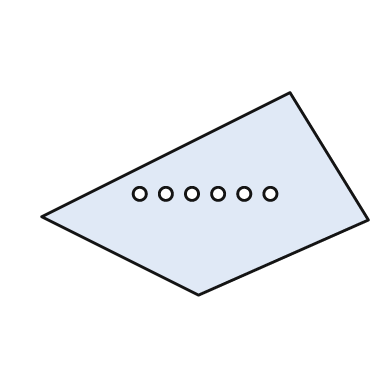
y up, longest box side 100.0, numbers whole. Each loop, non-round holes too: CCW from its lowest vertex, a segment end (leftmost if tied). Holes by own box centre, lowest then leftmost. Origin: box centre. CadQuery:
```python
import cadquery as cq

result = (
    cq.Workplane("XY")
    .moveTo(-2.0, -31.0)
    .lineTo(50.0, -8.0)
    .lineTo(26.0, 31.0)
    .lineTo(-50.0, -7.0)
    .close()
    .moveTo(-20.0, 0.0)
    .circle(2.0)
    .moveTo(-12.0, 0.0)
    .circle(2.0)
    .moveTo(-4.0, 0.0)
    .circle(2.0)
    .moveTo(4.0, 0.0)
    .circle(2.0)
    .moveTo(12.0, 0.0)
    .circle(2.0)
    .moveTo(20.0, 0.0)
    .circle(2.0)
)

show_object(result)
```